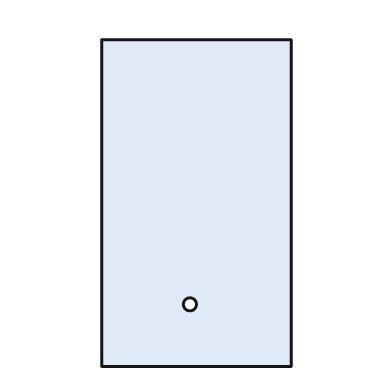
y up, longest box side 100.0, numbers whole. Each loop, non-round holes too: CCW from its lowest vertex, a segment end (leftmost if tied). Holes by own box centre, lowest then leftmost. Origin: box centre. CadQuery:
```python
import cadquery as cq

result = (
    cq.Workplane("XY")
    .moveTo(-29.0, -50.0)
    .lineTo(29.0, -50.0)
    .lineTo(29.0, 50.0)
    .lineTo(-29.0, 50.0)
    .close()
    .moveTo(-2.0, -31.0)
    .circle(2.0)
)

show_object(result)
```